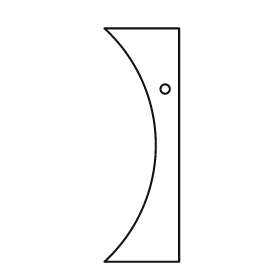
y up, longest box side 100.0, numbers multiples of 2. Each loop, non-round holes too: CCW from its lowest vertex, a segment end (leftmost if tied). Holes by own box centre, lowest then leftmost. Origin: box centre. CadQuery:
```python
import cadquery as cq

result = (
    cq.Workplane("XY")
    .moveTo(-16.0, -50.0)
    .lineTo(16.0, -50.0)
    .lineTo(16.0, 50.0)
    .lineTo(-16.0, 50.0)
    .threePointArc((6.0, 0.0), (-16.0, -50.0))
    .close()
    .moveTo(10.0, 24.0)
    .circle(2.0)
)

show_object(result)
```